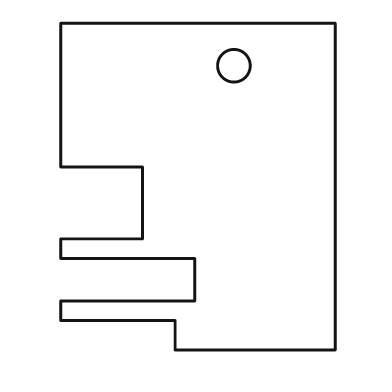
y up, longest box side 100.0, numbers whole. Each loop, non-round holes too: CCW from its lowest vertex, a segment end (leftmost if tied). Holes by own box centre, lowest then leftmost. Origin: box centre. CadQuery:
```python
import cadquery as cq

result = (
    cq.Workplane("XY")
    .moveTo(-7.0, -50.0)
    .lineTo(42.0, -50.0)
    .lineTo(42.0, 50.0)
    .lineTo(-42.0, 50.0)
    .lineTo(-42.0, 6.0)
    .lineTo(-17.0, 6.0)
    .lineTo(-17.0, -16.0)
    .lineTo(-42.0, -16.0)
    .lineTo(-42.0, -22.0)
    .lineTo(-1.0, -22.0)
    .lineTo(-1.0, -35.0)
    .lineTo(-42.0, -35.0)
    .lineTo(-42.0, -41.0)
    .lineTo(-7.0, -41.0)
    .close()
    .moveTo(11.0, 37.0)
    .circle(5.0)
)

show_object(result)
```